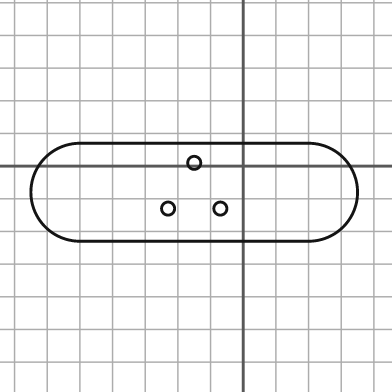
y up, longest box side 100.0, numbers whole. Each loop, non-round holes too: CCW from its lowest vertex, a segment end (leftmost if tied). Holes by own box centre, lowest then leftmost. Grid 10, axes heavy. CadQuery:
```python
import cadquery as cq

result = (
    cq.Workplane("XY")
    .moveTo(-50.0, -23.0)
    .lineTo(20.0, -23.0)
    .threePointArc((35.0, -8.0), (20.0, 7.0))
    .lineTo(-50.0, 7.0)
    .threePointArc((-65.0, -8.0), (-50.0, -23.0))
    .close()
    .moveTo(-23.0, -13.0)
    .circle(2.0)
    .moveTo(-7.0, -13.0)
    .circle(2.0)
    .moveTo(-15.0, 1.0)
    .circle(2.0)
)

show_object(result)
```